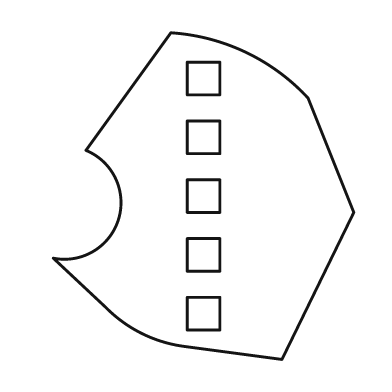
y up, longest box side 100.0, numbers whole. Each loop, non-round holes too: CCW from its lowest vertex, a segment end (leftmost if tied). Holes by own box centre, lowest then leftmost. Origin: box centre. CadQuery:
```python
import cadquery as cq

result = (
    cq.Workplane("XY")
    .moveTo(24.0, -50.0)
    .lineTo(46.0, -5.0)
    .lineTo(32.0, 30.0)
    .threePointArc((13.0, 44.0), (-10.0, 50.0))
    .lineTo(-36.0, 14.0)
    .threePointArc((-26.0, -7.0), (-46.0, -19.0))
    .lineTo(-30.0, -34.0)
    .threePointArc((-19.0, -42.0), (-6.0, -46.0))
    .close()
    .moveTo(-5.0, -41.0)
    .lineTo(5.0, -41.0)
    .lineTo(5.0, -31.0)
    .lineTo(-5.0, -31.0)
    .close()
    .moveTo(-5.0, -23.0)
    .lineTo(5.0, -23.0)
    .lineTo(5.0, -13.0)
    .lineTo(-5.0, -13.0)
    .close()
    .moveTo(-5.0, -5.0)
    .lineTo(5.0, -5.0)
    .lineTo(5.0, 5.0)
    .lineTo(-5.0, 5.0)
    .close()
    .moveTo(-5.0, 13.0)
    .lineTo(5.0, 13.0)
    .lineTo(5.0, 23.0)
    .lineTo(-5.0, 23.0)
    .close()
    .moveTo(-5.0, 31.0)
    .lineTo(5.0, 31.0)
    .lineTo(5.0, 41.0)
    .lineTo(-5.0, 41.0)
    .close()
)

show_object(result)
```